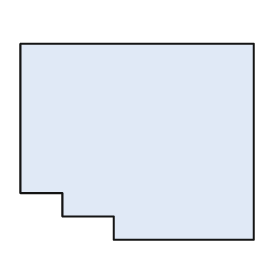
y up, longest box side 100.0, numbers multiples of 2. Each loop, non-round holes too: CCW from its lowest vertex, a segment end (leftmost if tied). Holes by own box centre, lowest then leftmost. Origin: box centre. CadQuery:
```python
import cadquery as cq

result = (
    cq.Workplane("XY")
    .moveTo(-10.0, -42.0)
    .lineTo(50.0, -42.0)
    .lineTo(50.0, 42.0)
    .lineTo(-50.0, 42.0)
    .lineTo(-50.0, -22.0)
    .lineTo(-32.0, -22.0)
    .lineTo(-32.0, -32.0)
    .lineTo(-10.0, -32.0)
    .close()
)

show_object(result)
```